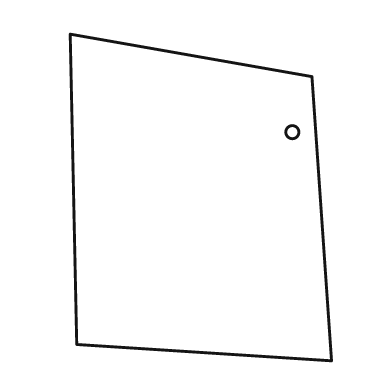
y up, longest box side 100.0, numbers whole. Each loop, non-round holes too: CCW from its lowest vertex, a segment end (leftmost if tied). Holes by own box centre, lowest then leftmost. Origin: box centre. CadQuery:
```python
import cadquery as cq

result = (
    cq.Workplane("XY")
    .moveTo(40.0, -50.0)
    .lineTo(34.0, 37.0)
    .lineTo(-40.0, 50.0)
    .lineTo(-38.0, -45.0)
    .close()
    .moveTo(28.0, 20.0)
    .circle(2.0)
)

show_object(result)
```